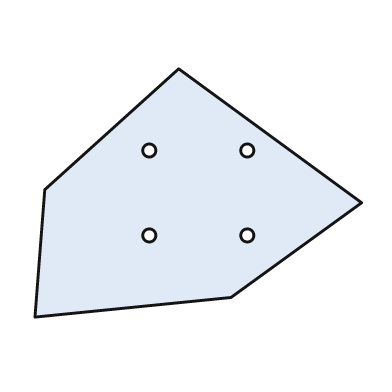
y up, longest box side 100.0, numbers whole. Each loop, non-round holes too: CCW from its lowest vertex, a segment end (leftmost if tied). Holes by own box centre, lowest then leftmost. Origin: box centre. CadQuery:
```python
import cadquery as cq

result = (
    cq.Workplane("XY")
    .moveTo(-50.0, -38.0)
    .lineTo(10.0, -32.0)
    .lineTo(50.0, -3.0)
    .lineTo(-6.0, 38.0)
    .lineTo(-47.0, 1.0)
    .close()
    .moveTo(-15.0, -13.0)
    .circle(2.0)
    .moveTo(15.0, -13.0)
    .circle(2.0)
    .moveTo(-15.0, 13.0)
    .circle(2.0)
    .moveTo(15.0, 13.0)
    .circle(2.0)
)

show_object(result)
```